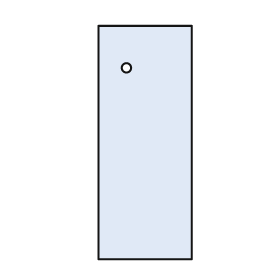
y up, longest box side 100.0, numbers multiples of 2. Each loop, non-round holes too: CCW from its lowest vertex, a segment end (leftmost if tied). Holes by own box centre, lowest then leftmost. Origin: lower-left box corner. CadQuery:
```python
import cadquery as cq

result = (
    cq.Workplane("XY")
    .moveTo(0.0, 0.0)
    .lineTo(40.0, 0.0)
    .lineTo(40.0, 100.0)
    .lineTo(0.0, 100.0)
    .close()
    .moveTo(12.0, 82.0)
    .circle(2.0)
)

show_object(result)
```